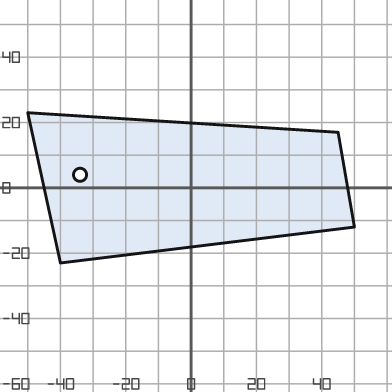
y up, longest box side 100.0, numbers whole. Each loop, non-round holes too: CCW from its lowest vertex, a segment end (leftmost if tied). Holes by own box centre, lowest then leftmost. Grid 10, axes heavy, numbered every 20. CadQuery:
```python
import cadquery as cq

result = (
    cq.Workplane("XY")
    .moveTo(-40.0, -23.0)
    .lineTo(50.0, -12.0)
    .lineTo(45.0, 17.0)
    .lineTo(-50.0, 23.0)
    .close()
    .moveTo(-34.0, 4.0)
    .circle(2.0)
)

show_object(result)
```